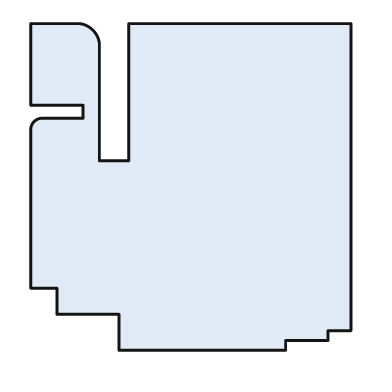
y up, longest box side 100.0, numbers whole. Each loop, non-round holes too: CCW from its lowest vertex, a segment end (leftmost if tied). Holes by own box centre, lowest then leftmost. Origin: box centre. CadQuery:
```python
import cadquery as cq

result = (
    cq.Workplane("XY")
    .moveTo(-22.0, -50.0)
    .lineTo(29.0, -50.0)
    .lineTo(29.0, -47.0)
    .lineTo(42.0, -47.0)
    .lineTo(42.0, -44.0)
    .lineTo(49.0, -44.0)
    .lineTo(49.0, 50.0)
    .lineTo(-19.0, 50.0)
    .lineTo(-19.0, 8.0)
    .lineTo(-28.0, 8.0)
    .lineTo(-28.0, 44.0)
    .threePointArc((-30.0, 48.0), (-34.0, 50.0))
    .lineTo(-49.0, 50.0)
    .lineTo(-49.0, 25.0)
    .lineTo(-33.0, 25.0)
    .lineTo(-33.0, 21.0)
    .lineTo(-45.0, 21.0)
    .threePointArc((-48.0, 20.0), (-49.0, 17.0))
    .lineTo(-49.0, -31.0)
    .lineTo(-41.0, -31.0)
    .lineTo(-41.0, -39.0)
    .lineTo(-22.0, -39.0)
    .close()
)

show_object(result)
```